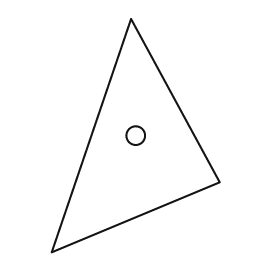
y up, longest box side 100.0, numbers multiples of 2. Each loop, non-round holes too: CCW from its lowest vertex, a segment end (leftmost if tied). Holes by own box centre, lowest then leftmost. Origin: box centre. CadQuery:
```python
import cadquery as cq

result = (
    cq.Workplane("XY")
    .moveTo(-36.0, -50.0)
    .lineTo(36.0, -20.0)
    .lineTo(-2.0, 50.0)
    .close()
    .moveTo(0.0, 0.0)
    .circle(4.0)
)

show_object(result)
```